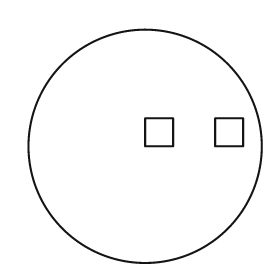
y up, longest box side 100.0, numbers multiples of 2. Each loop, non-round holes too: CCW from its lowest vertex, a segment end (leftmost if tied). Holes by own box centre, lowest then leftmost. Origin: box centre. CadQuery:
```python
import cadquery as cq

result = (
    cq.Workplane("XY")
    .moveTo(0.0, 0.0)
    .circle(50.0)
    .moveTo(0.0, 0.0)
    .lineTo(12.0, 0.0)
    .lineTo(12.0, 12.0)
    .lineTo(0.0, 12.0)
    .close()
    .moveTo(30.0, 0.0)
    .lineTo(42.0, 0.0)
    .lineTo(42.0, 12.0)
    .lineTo(30.0, 12.0)
    .close()
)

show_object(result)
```